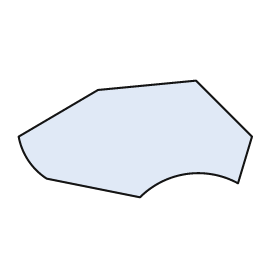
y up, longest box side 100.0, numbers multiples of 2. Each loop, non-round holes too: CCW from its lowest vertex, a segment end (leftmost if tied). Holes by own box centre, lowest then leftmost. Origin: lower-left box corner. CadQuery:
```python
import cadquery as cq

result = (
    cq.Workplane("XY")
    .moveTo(52.0, 0.0)
    .threePointArc((72.0, 10.0), (94.0, 6.0))
    .lineTo(100.0, 26.0)
    .lineTo(76.0, 50.0)
    .lineTo(34.0, 46.0)
    .lineTo(0.0, 26.0)
    .threePointArc((4.0, 16.0), (12.0, 8.0))
    .close()
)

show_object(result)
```